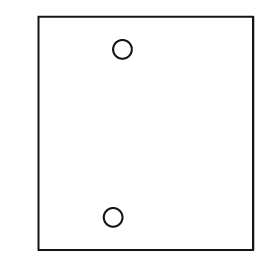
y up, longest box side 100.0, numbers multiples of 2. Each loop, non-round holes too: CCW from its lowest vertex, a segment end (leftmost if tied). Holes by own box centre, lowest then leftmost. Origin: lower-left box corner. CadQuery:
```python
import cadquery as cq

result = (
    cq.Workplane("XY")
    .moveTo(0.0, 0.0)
    .lineTo(92.0, 0.0)
    .lineTo(92.0, 100.0)
    .lineTo(0.0, 100.0)
    .close()
    .moveTo(32.0, 14.0)
    .circle(4.0)
    .moveTo(36.0, 86.0)
    .circle(4.0)
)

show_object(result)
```